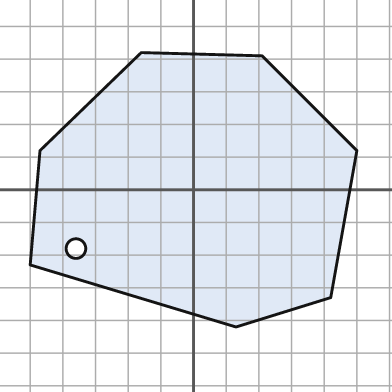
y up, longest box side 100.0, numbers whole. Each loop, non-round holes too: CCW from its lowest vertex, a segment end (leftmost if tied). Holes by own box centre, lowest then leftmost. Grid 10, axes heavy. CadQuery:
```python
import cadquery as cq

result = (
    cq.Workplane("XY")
    .moveTo(13.0, -42.0)
    .lineTo(42.0, -33.0)
    .lineTo(50.0, 12.0)
    .lineTo(21.0, 41.0)
    .lineTo(-16.0, 42.0)
    .lineTo(-47.0, 12.0)
    .lineTo(-50.0, -23.0)
    .close()
    .moveTo(-36.0, -18.0)
    .circle(3.0)
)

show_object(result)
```